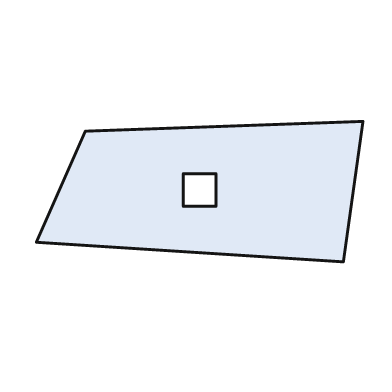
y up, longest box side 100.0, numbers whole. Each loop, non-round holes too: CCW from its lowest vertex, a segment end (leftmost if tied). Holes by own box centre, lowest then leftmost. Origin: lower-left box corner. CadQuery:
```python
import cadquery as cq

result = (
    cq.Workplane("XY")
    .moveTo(94.0, 0.0)
    .lineTo(100.0, 43.0)
    .lineTo(15.0, 40.0)
    .lineTo(0.0, 6.0)
    .close()
    .moveTo(45.0, 17.0)
    .lineTo(55.0, 17.0)
    .lineTo(55.0, 27.0)
    .lineTo(45.0, 27.0)
    .close()
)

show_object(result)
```